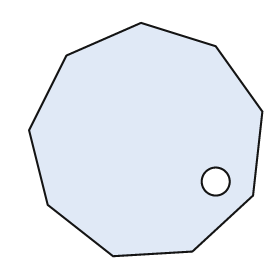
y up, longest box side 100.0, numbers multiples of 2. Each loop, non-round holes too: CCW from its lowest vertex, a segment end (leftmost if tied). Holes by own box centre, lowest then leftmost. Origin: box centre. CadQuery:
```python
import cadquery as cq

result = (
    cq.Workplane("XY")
    .moveTo(-14.0, -50.0)
    .lineTo(20.0, -48.0)
    .lineTo(46.0, -24.0)
    .lineTo(50.0, 12.0)
    .lineTo(30.0, 40.0)
    .lineTo(-2.0, 50.0)
    .lineTo(-34.0, 36.0)
    .lineTo(-50.0, 4.0)
    .lineTo(-42.0, -28.0)
    .close()
    .moveTo(30.0, -18.0)
    .circle(6.0)
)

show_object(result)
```